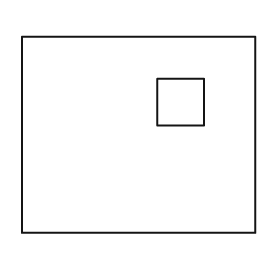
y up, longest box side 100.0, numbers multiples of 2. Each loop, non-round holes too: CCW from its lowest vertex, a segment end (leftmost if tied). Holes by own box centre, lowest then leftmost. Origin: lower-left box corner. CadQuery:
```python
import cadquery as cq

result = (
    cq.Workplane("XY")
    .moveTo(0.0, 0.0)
    .lineTo(100.0, 0.0)
    .lineTo(100.0, 84.0)
    .lineTo(0.0, 84.0)
    .close()
    .moveTo(58.0, 46.0)
    .lineTo(78.0, 46.0)
    .lineTo(78.0, 66.0)
    .lineTo(58.0, 66.0)
    .close()
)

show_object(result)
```